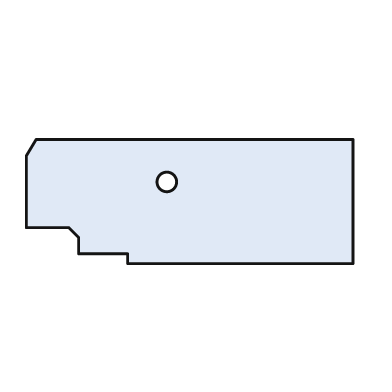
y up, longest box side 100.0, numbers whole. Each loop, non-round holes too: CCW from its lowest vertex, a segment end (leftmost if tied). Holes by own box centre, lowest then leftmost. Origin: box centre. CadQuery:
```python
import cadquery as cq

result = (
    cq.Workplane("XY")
    .moveTo(-19.0, -19.0)
    .lineTo(50.0, -19.0)
    .lineTo(50.0, 19.0)
    .lineTo(-47.0, 19.0)
    .lineTo(-50.0, 14.0)
    .lineTo(-50.0, -8.0)
    .lineTo(-37.0, -8.0)
    .lineTo(-34.0, -11.0)
    .lineTo(-34.0, -16.0)
    .lineTo(-19.0, -16.0)
    .close()
    .moveTo(-7.0, 6.0)
    .circle(3.0)
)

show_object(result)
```